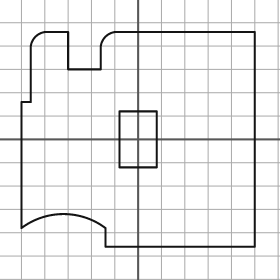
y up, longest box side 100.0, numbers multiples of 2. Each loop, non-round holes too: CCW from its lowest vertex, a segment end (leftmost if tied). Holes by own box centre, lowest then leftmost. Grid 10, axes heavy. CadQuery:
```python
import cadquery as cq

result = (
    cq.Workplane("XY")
    .moveTo(-14.0, -46.0)
    .lineTo(50.0, -46.0)
    .lineTo(50.0, 46.0)
    .lineTo(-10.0, 46.0)
    .threePointArc((-14.0, 44.0), (-16.0, 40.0))
    .lineTo(-16.0, 30.0)
    .lineTo(-30.0, 30.0)
    .lineTo(-30.0, 46.0)
    .lineTo(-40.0, 46.0)
    .threePointArc((-44.0, 44.0), (-46.0, 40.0))
    .lineTo(-46.0, 16.0)
    .lineTo(-50.0, 16.0)
    .lineTo(-50.0, -38.0)
    .threePointArc((-32.0, -32.0), (-14.0, -38.0))
    .close()
    .moveTo(-8.0, -12.0)
    .lineTo(8.0, -12.0)
    .lineTo(8.0, 12.0)
    .lineTo(-8.0, 12.0)
    .close()
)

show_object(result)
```